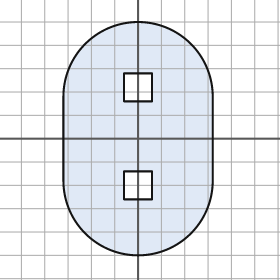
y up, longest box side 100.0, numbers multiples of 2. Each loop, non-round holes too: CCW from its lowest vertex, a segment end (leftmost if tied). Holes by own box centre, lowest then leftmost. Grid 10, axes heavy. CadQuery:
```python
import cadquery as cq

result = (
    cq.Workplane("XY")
    .moveTo(-32.0, -18.0)
    .threePointArc((0.0, -50.0), (32.0, -18.0))
    .lineTo(32.0, 18.0)
    .threePointArc((0.0, 50.0), (-32.0, 18.0))
    .close()
    .moveTo(-6.0, -26.0)
    .lineTo(6.0, -26.0)
    .lineTo(6.0, -14.0)
    .lineTo(-6.0, -14.0)
    .close()
    .moveTo(-6.0, 16.0)
    .lineTo(6.0, 16.0)
    .lineTo(6.0, 28.0)
    .lineTo(-6.0, 28.0)
    .close()
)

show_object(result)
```